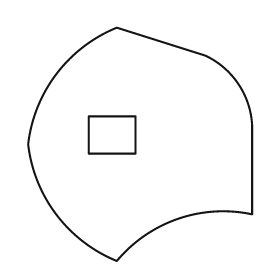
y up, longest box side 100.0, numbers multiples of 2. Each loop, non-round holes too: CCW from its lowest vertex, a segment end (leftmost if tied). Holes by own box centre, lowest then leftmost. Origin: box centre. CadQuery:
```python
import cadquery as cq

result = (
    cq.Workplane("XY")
    .moveTo(-10.0, -50.0)
    .threePointArc((16.0, -32.0), (48.0, -30.0))
    .lineTo(48.0, 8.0)
    .threePointArc((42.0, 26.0), (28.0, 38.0))
    .lineTo(-10.0, 50.0)
    .threePointArc((-36.0, 30.0), (-48.0, 0.0))
    .threePointArc((-36.0, -30.0), (-10.0, -50.0))
    .close()
    .moveTo(-22.0, -4.0)
    .lineTo(-2.0, -4.0)
    .lineTo(-2.0, 12.0)
    .lineTo(-22.0, 12.0)
    .close()
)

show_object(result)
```